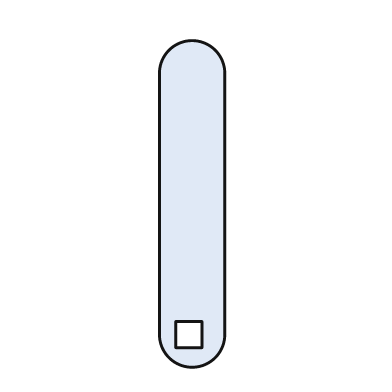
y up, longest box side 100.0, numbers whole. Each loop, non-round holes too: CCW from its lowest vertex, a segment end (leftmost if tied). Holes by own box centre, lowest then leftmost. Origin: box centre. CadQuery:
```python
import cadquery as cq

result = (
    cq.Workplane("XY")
    .moveTo(-10.0, -40.0)
    .threePointArc((0.0, -50.0), (10.0, -40.0))
    .lineTo(10.0, 40.0)
    .threePointArc((0.0, 50.0), (-10.0, 40.0))
    .close()
    .moveTo(-5.0, -44.0)
    .lineTo(3.0, -44.0)
    .lineTo(3.0, -36.0)
    .lineTo(-5.0, -36.0)
    .close()
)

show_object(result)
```